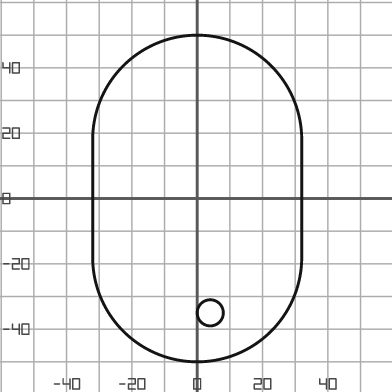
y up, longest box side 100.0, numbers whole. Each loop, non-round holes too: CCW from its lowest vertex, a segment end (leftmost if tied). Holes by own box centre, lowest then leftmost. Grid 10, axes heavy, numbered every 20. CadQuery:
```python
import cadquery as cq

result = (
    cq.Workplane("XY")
    .moveTo(-32.0, -18.0)
    .threePointArc((0.0, -50.0), (32.0, -18.0))
    .lineTo(32.0, 18.0)
    .threePointArc((0.0, 50.0), (-32.0, 18.0))
    .close()
    .moveTo(4.0, -35.0)
    .circle(4.0)
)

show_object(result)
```